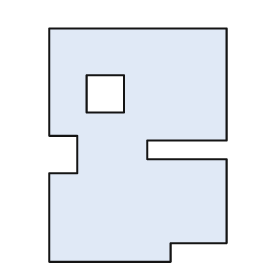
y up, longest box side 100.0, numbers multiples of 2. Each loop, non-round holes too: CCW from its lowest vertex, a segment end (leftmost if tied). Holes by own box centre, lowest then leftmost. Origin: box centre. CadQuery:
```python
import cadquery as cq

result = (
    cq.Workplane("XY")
    .moveTo(-38.0, -50.0)
    .lineTo(14.0, -50.0)
    .lineTo(14.0, -42.0)
    .lineTo(38.0, -42.0)
    .lineTo(38.0, -6.0)
    .lineTo(4.0, -6.0)
    .lineTo(4.0, 2.0)
    .lineTo(38.0, 2.0)
    .lineTo(38.0, 50.0)
    .lineTo(-38.0, 50.0)
    .lineTo(-38.0, 4.0)
    .lineTo(-26.0, 4.0)
    .lineTo(-26.0, -12.0)
    .lineTo(-38.0, -12.0)
    .close()
    .moveTo(-22.0, 14.0)
    .lineTo(-6.0, 14.0)
    .lineTo(-6.0, 30.0)
    .lineTo(-22.0, 30.0)
    .close()
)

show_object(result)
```